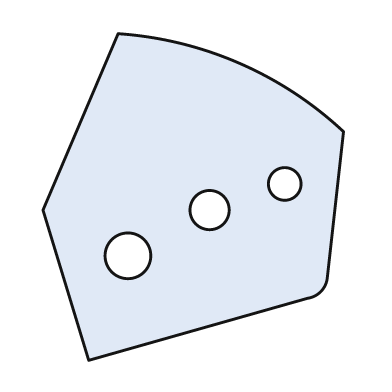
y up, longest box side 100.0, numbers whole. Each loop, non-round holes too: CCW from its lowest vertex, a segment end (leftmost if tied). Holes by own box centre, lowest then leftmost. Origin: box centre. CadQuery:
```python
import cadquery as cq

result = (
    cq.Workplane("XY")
    .moveTo(-32.0, -50.0)
    .lineTo(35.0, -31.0)
    .threePointArc((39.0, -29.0), (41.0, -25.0))
    .lineTo(46.0, 20.0)
    .threePointArc((14.0, 41.0), (-23.0, 50.0))
    .lineTo(-46.0, -4.0)
    .close()
    .moveTo(-20.0, -18.0)
    .circle(7.0)
    .moveTo(5.0, -4.0)
    .circle(6.0)
    .moveTo(28.0, 4.0)
    .circle(5.0)
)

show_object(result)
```